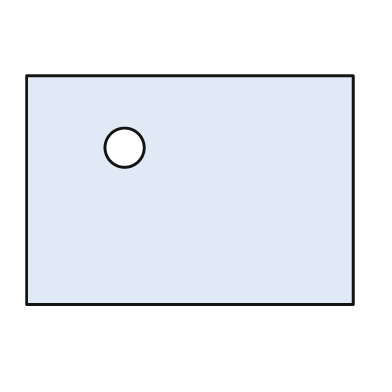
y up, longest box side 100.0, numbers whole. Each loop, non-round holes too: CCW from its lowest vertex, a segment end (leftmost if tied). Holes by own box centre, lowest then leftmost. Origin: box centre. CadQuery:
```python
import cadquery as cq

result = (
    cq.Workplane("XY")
    .moveTo(-50.0, -35.0)
    .lineTo(50.0, -35.0)
    .lineTo(50.0, 35.0)
    .lineTo(-50.0, 35.0)
    .close()
    .moveTo(-20.0, 13.0)
    .circle(6.0)
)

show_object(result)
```